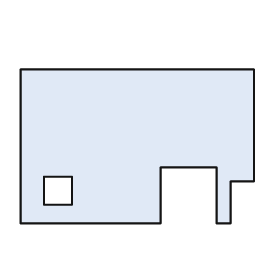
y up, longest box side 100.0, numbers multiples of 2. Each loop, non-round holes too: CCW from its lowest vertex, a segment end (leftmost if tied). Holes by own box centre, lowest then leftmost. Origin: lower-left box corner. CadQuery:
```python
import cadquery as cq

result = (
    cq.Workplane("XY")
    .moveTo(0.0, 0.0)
    .lineTo(60.0, 0.0)
    .lineTo(60.0, 24.0)
    .lineTo(84.0, 24.0)
    .lineTo(84.0, 0.0)
    .lineTo(90.0, 0.0)
    .lineTo(90.0, 18.0)
    .lineTo(100.0, 18.0)
    .lineTo(100.0, 66.0)
    .lineTo(0.0, 66.0)
    .close()
    .moveTo(10.0, 8.0)
    .lineTo(22.0, 8.0)
    .lineTo(22.0, 20.0)
    .lineTo(10.0, 20.0)
    .close()
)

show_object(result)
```